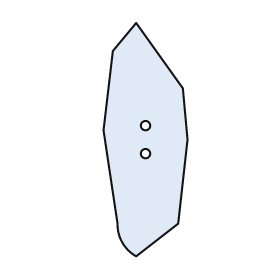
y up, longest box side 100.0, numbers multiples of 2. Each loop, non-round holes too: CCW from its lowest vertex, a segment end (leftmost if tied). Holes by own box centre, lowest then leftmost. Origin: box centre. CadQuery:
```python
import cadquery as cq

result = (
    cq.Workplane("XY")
    .moveTo(-4.0, -50.0)
    .lineTo(14.0, -36.0)
    .lineTo(18.0, 0.0)
    .lineTo(16.0, 22.0)
    .lineTo(-4.0, 50.0)
    .lineTo(-14.0, 38.0)
    .lineTo(-18.0, 4.0)
    .lineTo(-12.0, -36.0)
    .threePointArc((-10.0, -44.0), (-4.0, -50.0))
    .close()
    .moveTo(0.0, -6.0)
    .circle(2.0)
    .moveTo(0.0, 6.0)
    .circle(2.0)
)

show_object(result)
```